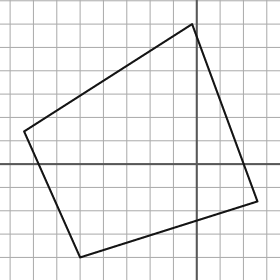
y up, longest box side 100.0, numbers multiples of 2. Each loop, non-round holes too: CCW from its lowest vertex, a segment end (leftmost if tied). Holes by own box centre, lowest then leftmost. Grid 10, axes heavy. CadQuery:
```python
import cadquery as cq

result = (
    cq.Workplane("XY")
    .moveTo(-50.0, -40.0)
    .lineTo(26.0, -16.0)
    .lineTo(-2.0, 60.0)
    .lineTo(-74.0, 14.0)
    .close()
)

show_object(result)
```